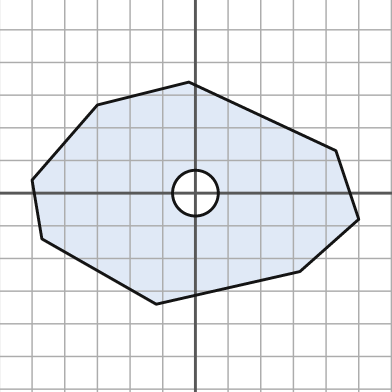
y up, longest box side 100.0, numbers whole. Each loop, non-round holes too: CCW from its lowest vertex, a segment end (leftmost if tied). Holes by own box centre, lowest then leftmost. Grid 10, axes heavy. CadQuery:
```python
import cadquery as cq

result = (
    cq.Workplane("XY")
    .moveTo(-12.0, -34.0)
    .lineTo(32.0, -24.0)
    .lineTo(50.0, -8.0)
    .lineTo(43.0, 13.0)
    .lineTo(-2.0, 34.0)
    .lineTo(-30.0, 27.0)
    .lineTo(-50.0, 4.0)
    .lineTo(-47.0, -14.0)
    .close()
    .moveTo(0.0, 0.0)
    .circle(7.0)
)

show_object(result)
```